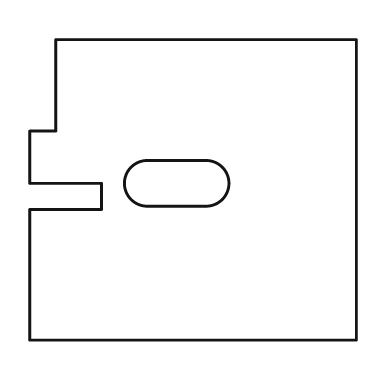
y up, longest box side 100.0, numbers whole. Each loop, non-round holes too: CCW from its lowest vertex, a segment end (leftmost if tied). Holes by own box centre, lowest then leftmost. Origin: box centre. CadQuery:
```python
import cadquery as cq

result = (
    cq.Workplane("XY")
    .moveTo(-50.0, -46.0)
    .lineTo(50.0, -46.0)
    .lineTo(50.0, 46.0)
    .lineTo(-42.0, 46.0)
    .lineTo(-42.0, 18.0)
    .lineTo(-50.0, 18.0)
    .lineTo(-50.0, 2.0)
    .lineTo(-28.0, 2.0)
    .lineTo(-28.0, -6.0)
    .lineTo(-50.0, -6.0)
    .close()
    .moveTo(-14.0, -5.0)
    .lineTo(4.0, -5.0)
    .threePointArc((11.0, 2.0), (4.0, 9.0))
    .lineTo(-14.0, 9.0)
    .threePointArc((-21.0, 2.0), (-14.0, -5.0))
    .close()
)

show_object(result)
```